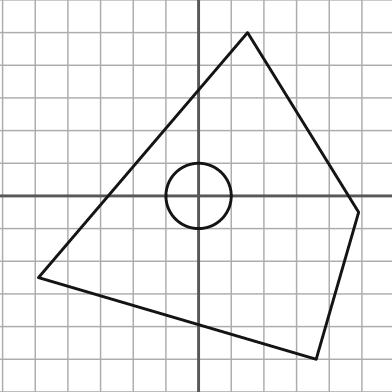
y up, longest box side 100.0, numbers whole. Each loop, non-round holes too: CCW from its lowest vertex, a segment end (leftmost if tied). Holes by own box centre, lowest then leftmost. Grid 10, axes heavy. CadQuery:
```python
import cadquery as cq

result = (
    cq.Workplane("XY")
    .moveTo(36.0, -50.0)
    .lineTo(49.0, -5.0)
    .lineTo(15.0, 50.0)
    .lineTo(-49.0, -25.0)
    .close()
    .moveTo(0.0, 0.0)
    .circle(10.0)
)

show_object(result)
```